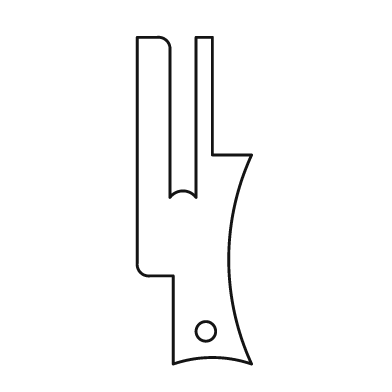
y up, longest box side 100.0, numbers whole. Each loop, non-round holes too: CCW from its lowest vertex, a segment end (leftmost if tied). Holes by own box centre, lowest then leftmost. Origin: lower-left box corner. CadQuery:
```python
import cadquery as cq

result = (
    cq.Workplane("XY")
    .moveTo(11.0, 0.0)
    .threePointArc((23.0, 2.0), (35.0, 0.0))
    .threePointArc((28.0, 32.0), (35.0, 64.0))
    .lineTo(23.0, 64.0)
    .lineTo(23.0, 100.0)
    .lineTo(18.0, 100.0)
    .lineTo(18.0, 51.0)
    .threePointArc((14.0, 53.0), (10.0, 51.0))
    .lineTo(10.0, 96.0)
    .threePointArc((9.0, 99.0), (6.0, 100.0))
    .lineTo(0.0, 100.0)
    .lineTo(0.0, 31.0)
    .threePointArc((1.0, 28.0), (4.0, 27.0))
    .lineTo(11.0, 27.0)
    .close()
    .moveTo(21.0, 10.0)
    .circle(3.0)
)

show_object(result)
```